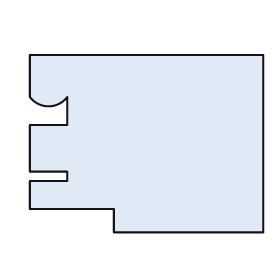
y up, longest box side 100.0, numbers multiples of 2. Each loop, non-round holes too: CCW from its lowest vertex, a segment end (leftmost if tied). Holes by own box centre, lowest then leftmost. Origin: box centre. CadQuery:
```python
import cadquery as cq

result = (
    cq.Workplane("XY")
    .moveTo(-14.0, -38.0)
    .lineTo(50.0, -38.0)
    .lineTo(50.0, 38.0)
    .lineTo(-50.0, 38.0)
    .lineTo(-50.0, 20.0)
    .threePointArc((-42.0, 16.0), (-34.0, 20.0))
    .lineTo(-34.0, 8.0)
    .lineTo(-50.0, 8.0)
    .lineTo(-50.0, -12.0)
    .lineTo(-34.0, -12.0)
    .lineTo(-34.0, -16.0)
    .lineTo(-50.0, -16.0)
    .lineTo(-50.0, -28.0)
    .lineTo(-14.0, -28.0)
    .close()
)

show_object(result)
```